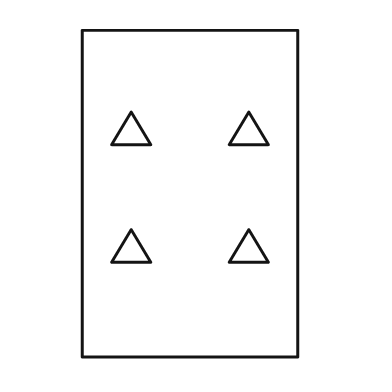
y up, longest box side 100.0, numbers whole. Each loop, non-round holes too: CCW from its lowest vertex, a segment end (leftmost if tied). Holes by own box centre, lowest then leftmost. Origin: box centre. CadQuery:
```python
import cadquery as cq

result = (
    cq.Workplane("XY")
    .moveTo(-33.0, -50.0)
    .lineTo(33.0, -50.0)
    .lineTo(33.0, 50.0)
    .lineTo(-33.0, 50.0)
    .close()
    .moveTo(-24.0, -21.0)
    .lineTo(-12.0, -21.0)
    .lineTo(-18.0, -11.0)
    .close()
    .moveTo(12.0, -21.0)
    .lineTo(24.0, -21.0)
    .lineTo(18.0, -11.0)
    .close()
    .moveTo(-24.0, 15.0)
    .lineTo(-12.0, 15.0)
    .lineTo(-18.0, 25.0)
    .close()
    .moveTo(12.0, 15.0)
    .lineTo(24.0, 15.0)
    .lineTo(18.0, 25.0)
    .close()
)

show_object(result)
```